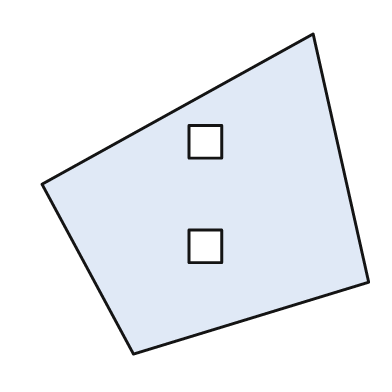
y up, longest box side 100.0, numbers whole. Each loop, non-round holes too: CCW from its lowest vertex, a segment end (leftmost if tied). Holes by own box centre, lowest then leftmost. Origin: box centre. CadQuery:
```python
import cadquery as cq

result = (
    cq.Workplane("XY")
    .moveTo(-22.0, -49.0)
    .lineTo(50.0, -27.0)
    .lineTo(33.0, 49.0)
    .lineTo(-50.0, 3.0)
    .close()
    .moveTo(-5.0, -21.0)
    .lineTo(5.0, -21.0)
    .lineTo(5.0, -11.0)
    .lineTo(-5.0, -11.0)
    .close()
    .moveTo(-5.0, 11.0)
    .lineTo(5.0, 11.0)
    .lineTo(5.0, 21.0)
    .lineTo(-5.0, 21.0)
    .close()
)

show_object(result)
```